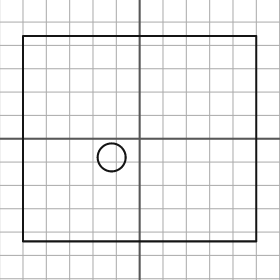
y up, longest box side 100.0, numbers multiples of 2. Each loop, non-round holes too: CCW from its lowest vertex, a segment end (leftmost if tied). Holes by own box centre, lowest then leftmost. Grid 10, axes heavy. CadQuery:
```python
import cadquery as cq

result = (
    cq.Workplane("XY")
    .moveTo(-50.0, -44.0)
    .lineTo(50.0, -44.0)
    .lineTo(50.0, 44.0)
    .lineTo(-50.0, 44.0)
    .close()
    .moveTo(-12.0, -8.0)
    .circle(6.0)
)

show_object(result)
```